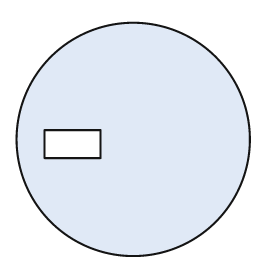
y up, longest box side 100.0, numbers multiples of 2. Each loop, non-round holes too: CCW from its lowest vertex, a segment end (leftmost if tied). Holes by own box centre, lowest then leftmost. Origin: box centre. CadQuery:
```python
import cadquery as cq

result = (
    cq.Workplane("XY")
    .moveTo(0.0, 0.0)
    .circle(50.0)
    .moveTo(-38.0, -8.0)
    .lineTo(-14.0, -8.0)
    .lineTo(-14.0, 4.0)
    .lineTo(-38.0, 4.0)
    .close()
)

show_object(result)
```